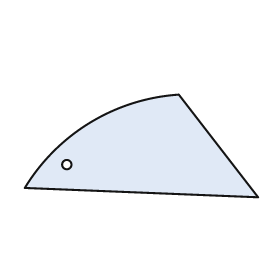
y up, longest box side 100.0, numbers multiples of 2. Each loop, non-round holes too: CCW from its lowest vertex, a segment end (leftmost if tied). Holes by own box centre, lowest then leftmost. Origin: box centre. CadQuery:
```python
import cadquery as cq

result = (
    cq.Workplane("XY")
    .moveTo(50.0, -22.0)
    .lineTo(16.0, 22.0)
    .threePointArc((-22.0, 10.0), (-50.0, -18.0))
    .close()
    .moveTo(-32.0, -8.0)
    .circle(2.0)
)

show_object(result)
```